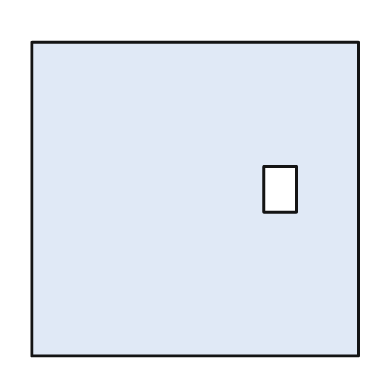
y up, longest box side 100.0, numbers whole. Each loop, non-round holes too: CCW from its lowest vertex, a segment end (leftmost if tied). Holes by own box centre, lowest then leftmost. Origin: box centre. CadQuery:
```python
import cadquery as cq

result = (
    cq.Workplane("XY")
    .moveTo(-50.0, -48.0)
    .lineTo(50.0, -48.0)
    .lineTo(50.0, 48.0)
    .lineTo(-50.0, 48.0)
    .close()
    .moveTo(21.0, -4.0)
    .lineTo(31.0, -4.0)
    .lineTo(31.0, 10.0)
    .lineTo(21.0, 10.0)
    .close()
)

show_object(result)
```